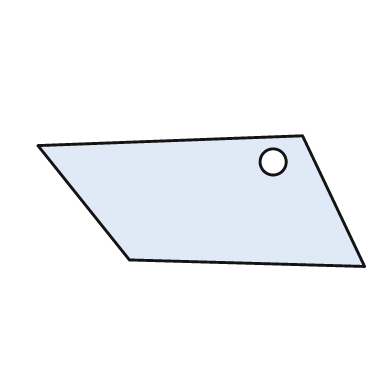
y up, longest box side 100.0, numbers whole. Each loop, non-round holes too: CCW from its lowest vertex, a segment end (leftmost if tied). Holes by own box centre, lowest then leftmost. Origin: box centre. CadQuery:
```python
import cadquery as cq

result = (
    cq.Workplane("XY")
    .moveTo(50.0, -20.0)
    .lineTo(31.0, 20.0)
    .lineTo(-50.0, 17.0)
    .lineTo(-22.0, -18.0)
    .close()
    .moveTo(22.0, 12.0)
    .circle(4.0)
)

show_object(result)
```